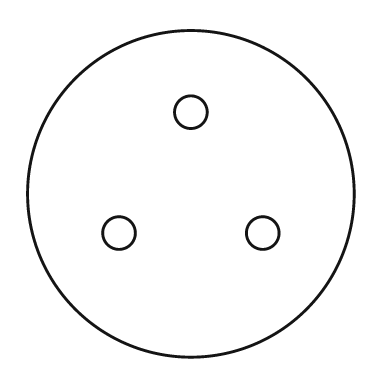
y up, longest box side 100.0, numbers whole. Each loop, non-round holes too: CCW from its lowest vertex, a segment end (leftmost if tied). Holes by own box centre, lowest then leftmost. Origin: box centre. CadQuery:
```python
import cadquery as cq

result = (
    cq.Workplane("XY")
    .moveTo(0.0, 0.0)
    .circle(50.0)
    .moveTo(-22.0, -12.0)
    .circle(5.0)
    .moveTo(22.0, -12.0)
    .circle(5.0)
    .moveTo(0.0, 25.0)
    .circle(5.0)
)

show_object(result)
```